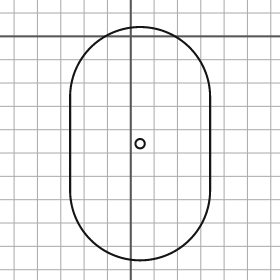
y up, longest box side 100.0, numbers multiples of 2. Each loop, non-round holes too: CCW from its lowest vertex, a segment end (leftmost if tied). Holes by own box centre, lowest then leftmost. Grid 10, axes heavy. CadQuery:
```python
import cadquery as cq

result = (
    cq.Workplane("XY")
    .moveTo(-26.0, -66.0)
    .threePointArc((4.0, -96.0), (34.0, -66.0))
    .lineTo(34.0, -26.0)
    .threePointArc((4.0, 4.0), (-26.0, -26.0))
    .close()
    .moveTo(4.0, -46.0)
    .circle(2.0)
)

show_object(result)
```